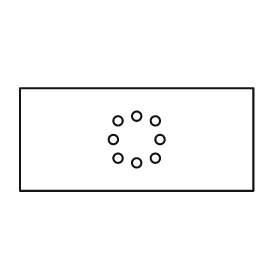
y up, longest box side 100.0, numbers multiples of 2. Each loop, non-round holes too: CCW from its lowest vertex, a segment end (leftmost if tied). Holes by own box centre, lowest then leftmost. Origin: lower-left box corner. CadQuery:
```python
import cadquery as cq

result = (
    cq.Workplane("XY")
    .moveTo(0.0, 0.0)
    .lineTo(100.0, 0.0)
    .lineTo(100.0, 44.0)
    .lineTo(0.0, 44.0)
    .close()
    .moveTo(50.0, 12.0)
    .circle(2.0)
    .moveTo(42.0, 14.0)
    .circle(2.0)
    .moveTo(58.0, 14.0)
    .circle(2.0)
    .moveTo(40.0, 22.0)
    .circle(2.0)
    .moveTo(60.0, 22.0)
    .circle(2.0)
    .moveTo(42.0, 30.0)
    .circle(2.0)
    .moveTo(58.0, 30.0)
    .circle(2.0)
    .moveTo(50.0, 32.0)
    .circle(2.0)
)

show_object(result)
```